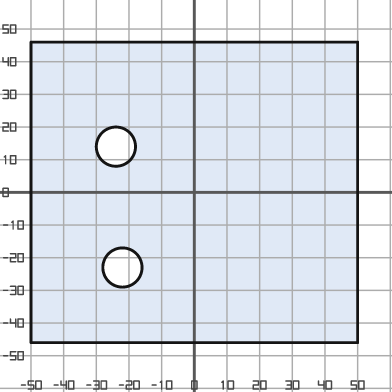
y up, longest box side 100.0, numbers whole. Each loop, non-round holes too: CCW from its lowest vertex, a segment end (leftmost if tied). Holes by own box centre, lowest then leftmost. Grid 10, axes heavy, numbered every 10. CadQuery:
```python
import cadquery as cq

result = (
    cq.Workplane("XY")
    .moveTo(-50.0, -46.0)
    .lineTo(50.0, -46.0)
    .lineTo(50.0, 46.0)
    .lineTo(-50.0, 46.0)
    .close()
    .moveTo(-22.0, -23.0)
    .circle(6.0)
    .moveTo(-24.0, 14.0)
    .circle(6.0)
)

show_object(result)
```